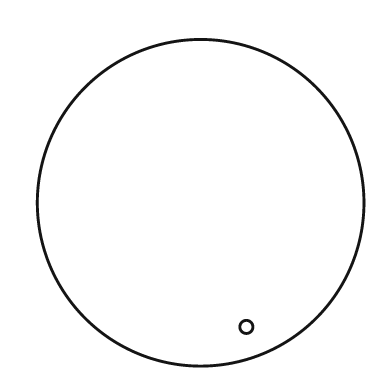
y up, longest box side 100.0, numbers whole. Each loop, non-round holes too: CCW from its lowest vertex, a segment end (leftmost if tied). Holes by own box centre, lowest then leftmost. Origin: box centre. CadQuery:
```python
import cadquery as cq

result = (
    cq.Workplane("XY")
    .moveTo(0.0, 0.0)
    .circle(50.0)
    .moveTo(14.0, -38.0)
    .circle(2.0)
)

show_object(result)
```